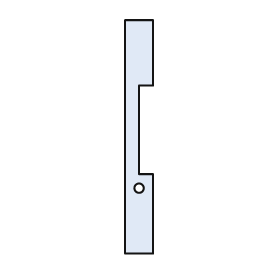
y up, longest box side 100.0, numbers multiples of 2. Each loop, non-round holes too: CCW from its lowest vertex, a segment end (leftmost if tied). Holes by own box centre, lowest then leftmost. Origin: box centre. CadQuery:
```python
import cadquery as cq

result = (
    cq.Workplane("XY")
    .moveTo(-6.0, -50.0)
    .lineTo(6.0, -50.0)
    .lineTo(6.0, -16.0)
    .lineTo(0.0, -16.0)
    .lineTo(0.0, 22.0)
    .lineTo(6.0, 22.0)
    .lineTo(6.0, 50.0)
    .lineTo(-6.0, 50.0)
    .close()
    .moveTo(0.0, -22.0)
    .circle(2.0)
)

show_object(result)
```